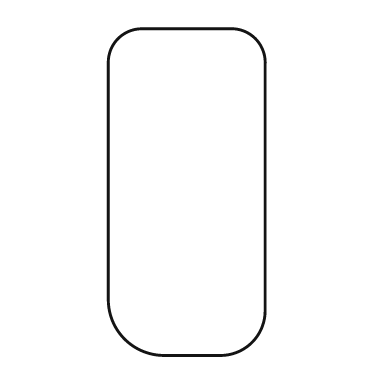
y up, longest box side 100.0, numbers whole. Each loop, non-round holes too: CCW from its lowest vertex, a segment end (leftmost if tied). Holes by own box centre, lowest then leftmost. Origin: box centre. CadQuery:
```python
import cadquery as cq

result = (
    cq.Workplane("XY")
    .moveTo(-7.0, -50.0)
    .lineTo(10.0, -50.0)
    .threePointArc((20.0, -46.0), (24.0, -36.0))
    .lineTo(24.0, 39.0)
    .threePointArc((21.0, 47.0), (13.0, 50.0))
    .lineTo(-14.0, 50.0)
    .threePointArc((-21.0, 47.0), (-24.0, 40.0))
    .lineTo(-24.0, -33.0)
    .threePointArc((-19.0, -45.0), (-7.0, -50.0))
    .close()
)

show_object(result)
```